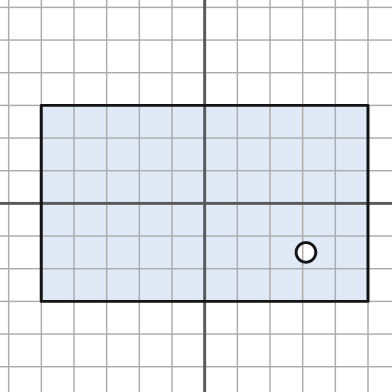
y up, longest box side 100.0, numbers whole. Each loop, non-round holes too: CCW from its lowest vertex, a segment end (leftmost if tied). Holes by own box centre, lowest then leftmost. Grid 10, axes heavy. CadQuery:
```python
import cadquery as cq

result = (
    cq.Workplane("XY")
    .moveTo(-50.0, -30.0)
    .lineTo(50.0, -30.0)
    .lineTo(50.0, 30.0)
    .lineTo(-50.0, 30.0)
    .close()
    .moveTo(31.0, -15.0)
    .circle(3.0)
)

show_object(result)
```